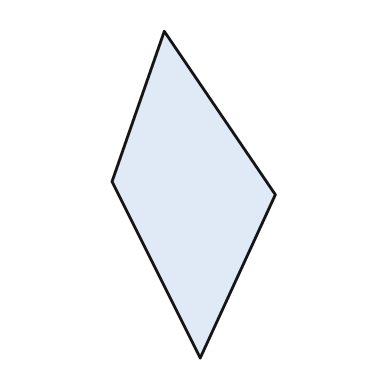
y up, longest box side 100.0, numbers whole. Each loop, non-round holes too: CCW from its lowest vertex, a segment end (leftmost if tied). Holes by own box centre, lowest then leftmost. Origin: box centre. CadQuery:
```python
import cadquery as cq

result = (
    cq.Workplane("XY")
    .moveTo(2.0, -50.0)
    .lineTo(25.0, 0.0)
    .lineTo(-9.0, 50.0)
    .lineTo(-25.0, 4.0)
    .close()
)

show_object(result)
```